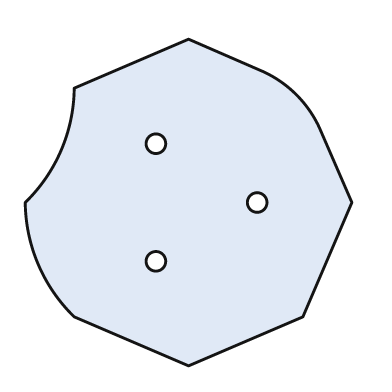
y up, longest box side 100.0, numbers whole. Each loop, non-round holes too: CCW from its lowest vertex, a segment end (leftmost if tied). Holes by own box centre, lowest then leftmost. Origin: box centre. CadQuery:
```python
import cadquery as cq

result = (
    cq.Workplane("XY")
    .moveTo(0.0, -50.0)
    .lineTo(35.0, -35.0)
    .lineTo(50.0, 0.0)
    .lineTo(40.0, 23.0)
    .threePointArc((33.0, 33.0), (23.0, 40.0))
    .lineTo(0.0, 50.0)
    .lineTo(-35.0, 35.0)
    .threePointArc((-39.0, 16.0), (-50.0, 0.0))
    .threePointArc((-46.0, -19.0), (-35.0, -35.0))
    .close()
    .moveTo(-10.0, -18.0)
    .circle(3.0)
    .moveTo(21.0, 0.0)
    .circle(3.0)
    .moveTo(-10.0, 18.0)
    .circle(3.0)
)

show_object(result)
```